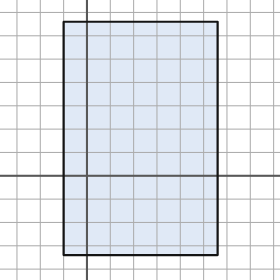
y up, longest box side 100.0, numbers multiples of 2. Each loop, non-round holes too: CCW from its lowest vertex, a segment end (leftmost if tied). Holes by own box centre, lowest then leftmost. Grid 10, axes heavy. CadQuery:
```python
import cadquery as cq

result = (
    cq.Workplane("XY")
    .moveTo(-10.0, -34.0)
    .lineTo(56.0, -34.0)
    .lineTo(56.0, 66.0)
    .lineTo(-10.0, 66.0)
    .close()
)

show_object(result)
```